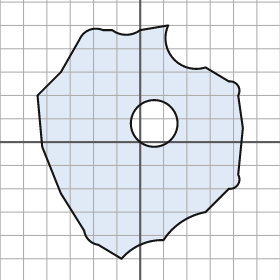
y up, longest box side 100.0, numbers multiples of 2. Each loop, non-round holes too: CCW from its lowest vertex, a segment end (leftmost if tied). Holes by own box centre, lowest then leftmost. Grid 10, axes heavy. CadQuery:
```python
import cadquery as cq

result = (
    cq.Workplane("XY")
    .moveTo(-8.0, -50.0)
    .threePointArc((0.0, -44.0), (10.0, -42.0))
    .threePointArc((18.0, -34.0), (28.0, -30.0))
    .lineTo(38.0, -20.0)
    .threePointArc((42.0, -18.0), (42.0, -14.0))
    .lineTo(44.0, 6.0)
    .lineTo(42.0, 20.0)
    .threePointArc((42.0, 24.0), (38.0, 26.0))
    .lineTo(28.0, 32.0)
    .threePointArc((14.0, 36.0), (12.0, 50.0))
    .lineTo(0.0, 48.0)
    .threePointArc((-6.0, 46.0), (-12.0, 48.0))
    .lineTo(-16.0, 48.0)
    .threePointArc((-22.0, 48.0), (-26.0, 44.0))
    .lineTo(-34.0, 30.0)
    .lineTo(-44.0, 20.0)
    .lineTo(-42.0, -2.0)
    .lineTo(-34.0, -22.0)
    .lineTo(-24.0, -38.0)
    .threePointArc((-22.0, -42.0), (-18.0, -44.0))
    .close()
    .moveTo(6.0, 8.0)
    .circle(10.0)
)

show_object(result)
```